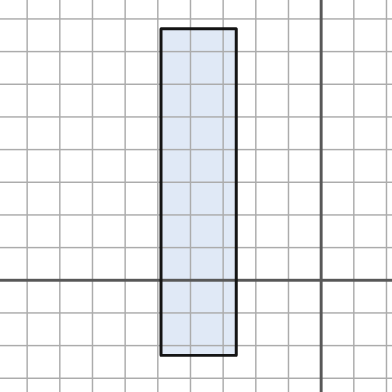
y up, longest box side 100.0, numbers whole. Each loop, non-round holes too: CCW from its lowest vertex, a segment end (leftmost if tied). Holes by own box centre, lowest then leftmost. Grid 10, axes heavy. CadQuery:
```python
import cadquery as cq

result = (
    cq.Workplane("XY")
    .moveTo(-49.0, -23.0)
    .lineTo(-26.0, -23.0)
    .lineTo(-26.0, 77.0)
    .lineTo(-49.0, 77.0)
    .close()
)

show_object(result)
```